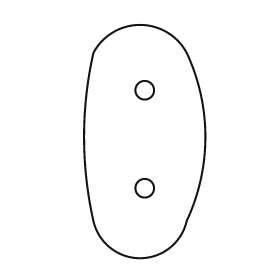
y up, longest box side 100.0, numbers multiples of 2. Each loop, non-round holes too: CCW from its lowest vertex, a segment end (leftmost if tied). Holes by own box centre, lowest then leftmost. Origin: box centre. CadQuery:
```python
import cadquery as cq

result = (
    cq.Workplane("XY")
    .moveTo(-22.0, -34.0)
    .threePointArc((-2.0, -50.0), (18.0, -34.0))
    .threePointArc((26.0, 2.0), (18.0, 38.0))
    .threePointArc((-2.0, 50.0), (-22.0, 38.0))
    .threePointArc((-26.0, 2.0), (-22.0, -34.0))
    .close()
    .moveTo(0.0, -20.0)
    .circle(4.0)
    .moveTo(0.0, 22.0)
    .circle(4.0)
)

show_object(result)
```